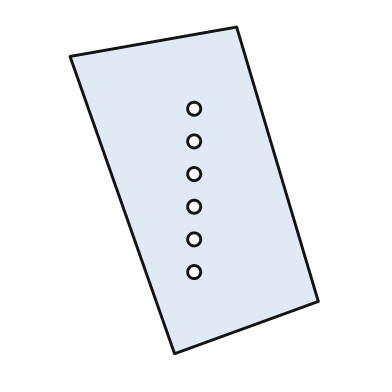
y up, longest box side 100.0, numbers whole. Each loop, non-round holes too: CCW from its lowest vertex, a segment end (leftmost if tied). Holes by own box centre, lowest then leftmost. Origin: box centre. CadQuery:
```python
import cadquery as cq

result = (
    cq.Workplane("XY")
    .moveTo(-6.0, -50.0)
    .lineTo(38.0, -34.0)
    .lineTo(13.0, 50.0)
    .lineTo(-38.0, 41.0)
    .close()
    .moveTo(0.0, -25.0)
    .circle(2.0)
    .moveTo(0.0, -15.0)
    .circle(2.0)
    .moveTo(0.0, -5.0)
    .circle(2.0)
    .moveTo(0.0, 5.0)
    .circle(2.0)
    .moveTo(0.0, 15.0)
    .circle(2.0)
    .moveTo(0.0, 25.0)
    .circle(2.0)
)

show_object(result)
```